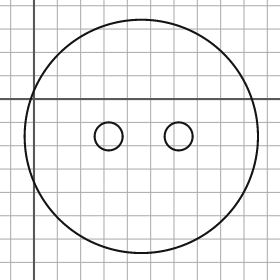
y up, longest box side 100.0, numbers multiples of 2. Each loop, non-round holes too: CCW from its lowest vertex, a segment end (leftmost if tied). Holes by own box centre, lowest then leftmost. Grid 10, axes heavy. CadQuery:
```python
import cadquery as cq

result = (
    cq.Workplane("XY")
    .moveTo(46.0, -16.0)
    .circle(50.0)
    .moveTo(32.0, -16.0)
    .circle(6.0)
    .moveTo(62.0, -16.0)
    .circle(6.0)
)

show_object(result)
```